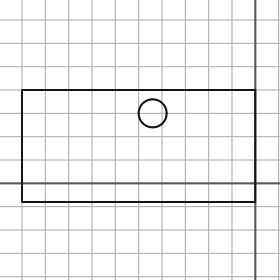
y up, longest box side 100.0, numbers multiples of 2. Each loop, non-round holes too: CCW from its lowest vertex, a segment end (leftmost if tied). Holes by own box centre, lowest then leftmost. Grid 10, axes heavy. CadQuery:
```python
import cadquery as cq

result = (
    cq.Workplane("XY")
    .moveTo(-100.0, -8.0)
    .lineTo(0.0, -8.0)
    .lineTo(0.0, 40.0)
    .lineTo(-100.0, 40.0)
    .close()
    .moveTo(-44.0, 30.0)
    .circle(6.0)
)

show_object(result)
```